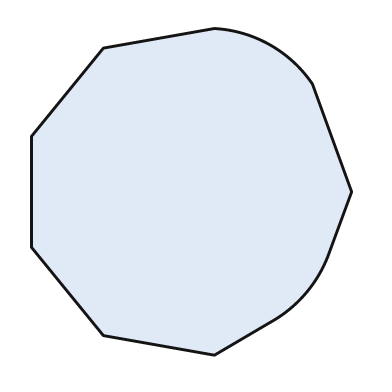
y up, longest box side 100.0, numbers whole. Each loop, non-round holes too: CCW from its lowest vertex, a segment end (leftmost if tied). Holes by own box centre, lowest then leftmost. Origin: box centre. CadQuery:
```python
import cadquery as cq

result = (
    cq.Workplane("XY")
    .moveTo(7.0, -50.0)
    .lineTo(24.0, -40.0)
    .threePointArc((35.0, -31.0), (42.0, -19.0))
    .lineTo(49.0, 0.0)
    .lineTo(37.0, 33.0)
    .threePointArc((24.0, 45.0), (7.0, 50.0))
    .lineTo(-27.0, 44.0)
    .lineTo(-49.0, 17.0)
    .lineTo(-49.0, -17.0)
    .lineTo(-27.0, -44.0)
    .close()
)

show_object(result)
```